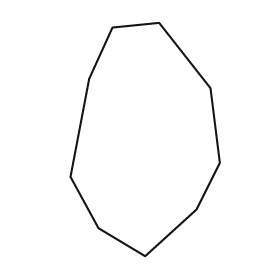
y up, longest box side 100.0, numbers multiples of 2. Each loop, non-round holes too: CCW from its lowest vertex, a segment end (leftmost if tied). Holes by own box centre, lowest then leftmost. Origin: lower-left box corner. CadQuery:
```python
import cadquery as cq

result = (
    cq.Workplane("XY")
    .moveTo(32.0, 0.0)
    .lineTo(54.0, 20.0)
    .lineTo(64.0, 40.0)
    .lineTo(60.0, 72.0)
    .lineTo(38.0, 100.0)
    .lineTo(18.0, 98.0)
    .lineTo(8.0, 76.0)
    .lineTo(0.0, 34.0)
    .lineTo(12.0, 12.0)
    .close()
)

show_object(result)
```